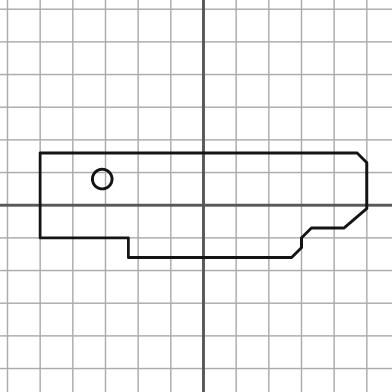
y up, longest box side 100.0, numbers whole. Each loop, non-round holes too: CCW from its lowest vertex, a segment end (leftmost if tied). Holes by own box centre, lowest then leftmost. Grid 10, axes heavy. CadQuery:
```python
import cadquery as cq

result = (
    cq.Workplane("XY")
    .moveTo(-23.0, -16.0)
    .lineTo(27.0, -16.0)
    .lineTo(30.0, -13.0)
    .lineTo(30.0, -10.0)
    .lineTo(33.0, -7.0)
    .lineTo(43.0, -7.0)
    .lineTo(50.0, -1.0)
    .lineTo(50.0, 13.0)
    .lineTo(47.0, 16.0)
    .lineTo(-50.0, 16.0)
    .lineTo(-50.0, -10.0)
    .lineTo(-23.0, -10.0)
    .close()
    .moveTo(-31.0, 8.0)
    .circle(3.0)
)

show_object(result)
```